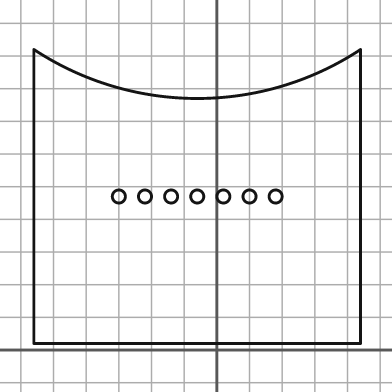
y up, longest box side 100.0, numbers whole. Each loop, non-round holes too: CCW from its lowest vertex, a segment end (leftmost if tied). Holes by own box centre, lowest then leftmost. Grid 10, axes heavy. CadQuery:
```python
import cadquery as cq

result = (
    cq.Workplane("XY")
    .moveTo(-56.0, 2.0)
    .lineTo(44.0, 2.0)
    .lineTo(44.0, 92.0)
    .threePointArc((-6.0, 77.0), (-56.0, 92.0))
    .close()
    .moveTo(-30.0, 47.0)
    .circle(2.0)
    .moveTo(-22.0, 47.0)
    .circle(2.0)
    .moveTo(-14.0, 47.0)
    .circle(2.0)
    .moveTo(-6.0, 47.0)
    .circle(2.0)
    .moveTo(2.0, 47.0)
    .circle(2.0)
    .moveTo(10.0, 47.0)
    .circle(2.0)
    .moveTo(18.0, 47.0)
    .circle(2.0)
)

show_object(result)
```